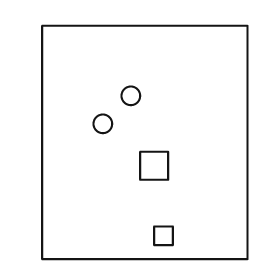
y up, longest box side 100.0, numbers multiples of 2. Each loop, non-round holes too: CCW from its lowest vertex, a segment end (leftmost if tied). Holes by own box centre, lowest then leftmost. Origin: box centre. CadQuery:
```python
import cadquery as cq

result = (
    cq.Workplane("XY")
    .moveTo(-44.0, -50.0)
    .lineTo(44.0, -50.0)
    .lineTo(44.0, 50.0)
    .lineTo(-44.0, 50.0)
    .close()
    .moveTo(4.0, -44.0)
    .lineTo(12.0, -44.0)
    .lineTo(12.0, -36.0)
    .lineTo(4.0, -36.0)
    .close()
    .moveTo(-2.0, -16.0)
    .lineTo(10.0, -16.0)
    .lineTo(10.0, -4.0)
    .lineTo(-2.0, -4.0)
    .close()
    .moveTo(-18.0, 8.0)
    .circle(4.0)
    .moveTo(-6.0, 20.0)
    .circle(4.0)
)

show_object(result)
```